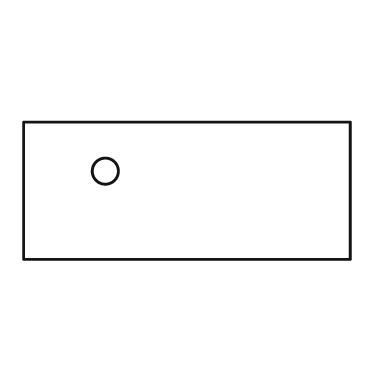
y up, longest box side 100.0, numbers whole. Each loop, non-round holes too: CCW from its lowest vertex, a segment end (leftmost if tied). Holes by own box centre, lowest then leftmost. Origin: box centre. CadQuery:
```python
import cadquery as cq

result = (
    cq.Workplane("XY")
    .moveTo(-50.0, -21.0)
    .lineTo(50.0, -21.0)
    .lineTo(50.0, 21.0)
    .lineTo(-50.0, 21.0)
    .close()
    .moveTo(-25.0, 6.0)
    .circle(4.0)
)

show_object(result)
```